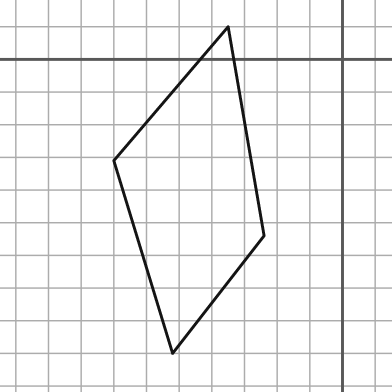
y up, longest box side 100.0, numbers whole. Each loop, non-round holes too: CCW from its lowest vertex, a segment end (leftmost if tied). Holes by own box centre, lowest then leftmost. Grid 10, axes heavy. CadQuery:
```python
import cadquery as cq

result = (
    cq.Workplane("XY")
    .moveTo(-52.0, -90.0)
    .lineTo(-24.0, -54.0)
    .lineTo(-35.0, 10.0)
    .lineTo(-70.0, -31.0)
    .close()
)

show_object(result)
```